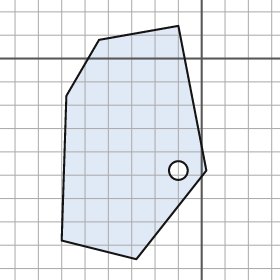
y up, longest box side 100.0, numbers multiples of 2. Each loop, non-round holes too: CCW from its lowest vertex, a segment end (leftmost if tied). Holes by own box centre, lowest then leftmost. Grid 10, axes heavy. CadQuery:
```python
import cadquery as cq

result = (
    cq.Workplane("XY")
    .moveTo(-28.0, -86.0)
    .lineTo(2.0, -48.0)
    .lineTo(-10.0, 14.0)
    .lineTo(-44.0, 8.0)
    .lineTo(-58.0, -16.0)
    .lineTo(-60.0, -78.0)
    .close()
    .moveTo(-10.0, -48.0)
    .circle(4.0)
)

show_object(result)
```